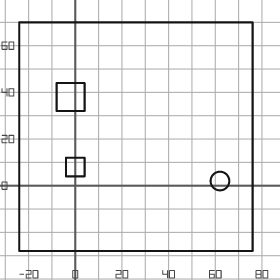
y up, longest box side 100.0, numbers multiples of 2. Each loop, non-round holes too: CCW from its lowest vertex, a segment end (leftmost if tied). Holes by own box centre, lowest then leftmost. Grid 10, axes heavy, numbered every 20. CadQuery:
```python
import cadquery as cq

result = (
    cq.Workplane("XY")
    .moveTo(-24.0, -28.0)
    .lineTo(76.0, -28.0)
    .lineTo(76.0, 70.0)
    .lineTo(-24.0, 70.0)
    .close()
    .moveTo(62.0, 2.0)
    .circle(4.0)
    .moveTo(-4.0, 4.0)
    .lineTo(4.0, 4.0)
    .lineTo(4.0, 12.0)
    .lineTo(-4.0, 12.0)
    .close()
    .moveTo(-8.0, 32.0)
    .lineTo(4.0, 32.0)
    .lineTo(4.0, 44.0)
    .lineTo(-8.0, 44.0)
    .close()
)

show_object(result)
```